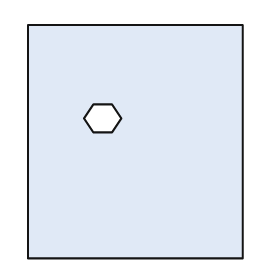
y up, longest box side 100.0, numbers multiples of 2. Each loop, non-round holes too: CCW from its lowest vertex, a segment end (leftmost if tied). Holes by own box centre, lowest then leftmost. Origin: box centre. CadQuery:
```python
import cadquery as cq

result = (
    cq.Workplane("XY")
    .moveTo(-46.0, -50.0)
    .lineTo(46.0, -50.0)
    .lineTo(46.0, 50.0)
    .lineTo(-46.0, 50.0)
    .close()
    .moveTo(-18.0, 4.0)
    .lineTo(-10.0, 4.0)
    .lineTo(-6.0, 10.0)
    .lineTo(-10.0, 16.0)
    .lineTo(-18.0, 16.0)
    .lineTo(-22.0, 10.0)
    .close()
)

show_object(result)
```